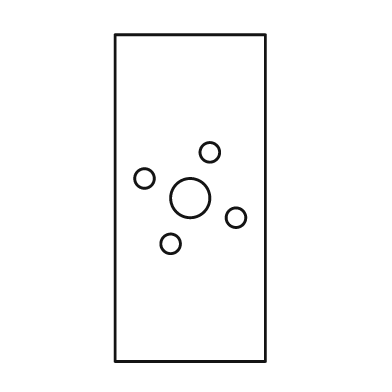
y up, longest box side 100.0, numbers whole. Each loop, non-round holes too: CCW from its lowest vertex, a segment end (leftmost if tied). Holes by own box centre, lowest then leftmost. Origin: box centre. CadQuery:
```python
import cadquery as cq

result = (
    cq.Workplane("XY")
    .moveTo(-23.0, -50.0)
    .lineTo(23.0, -50.0)
    .lineTo(23.0, 50.0)
    .lineTo(-23.0, 50.0)
    .close()
    .moveTo(-6.0, -14.0)
    .circle(3.0)
    .moveTo(14.0, -6.0)
    .circle(3.0)
    .moveTo(0.0, 0.0)
    .circle(6.0)
    .moveTo(-14.0, 6.0)
    .circle(3.0)
    .moveTo(6.0, 14.0)
    .circle(3.0)
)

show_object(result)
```